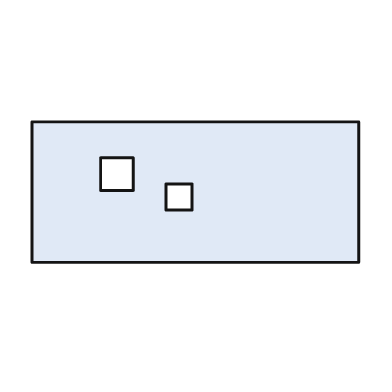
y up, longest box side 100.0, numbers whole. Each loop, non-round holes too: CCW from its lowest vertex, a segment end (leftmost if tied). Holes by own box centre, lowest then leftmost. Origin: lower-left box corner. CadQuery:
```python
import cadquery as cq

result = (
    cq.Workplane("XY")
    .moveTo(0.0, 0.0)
    .lineTo(100.0, 0.0)
    .lineTo(100.0, 43.0)
    .lineTo(0.0, 43.0)
    .close()
    .moveTo(41.0, 16.0)
    .lineTo(49.0, 16.0)
    .lineTo(49.0, 24.0)
    .lineTo(41.0, 24.0)
    .close()
    .moveTo(21.0, 22.0)
    .lineTo(31.0, 22.0)
    .lineTo(31.0, 32.0)
    .lineTo(21.0, 32.0)
    .close()
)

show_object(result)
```